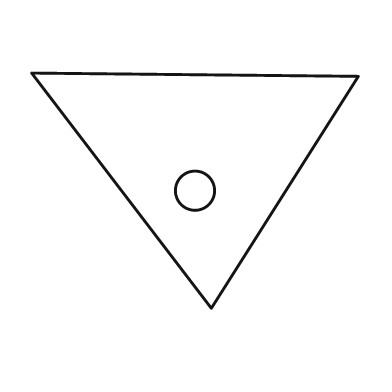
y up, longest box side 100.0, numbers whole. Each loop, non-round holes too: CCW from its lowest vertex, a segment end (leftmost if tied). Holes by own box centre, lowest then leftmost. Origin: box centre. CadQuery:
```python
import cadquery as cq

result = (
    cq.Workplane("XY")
    .moveTo(5.0, -36.0)
    .lineTo(50.0, 35.0)
    .lineTo(-50.0, 36.0)
    .close()
    .moveTo(0.0, 0.0)
    .circle(6.0)
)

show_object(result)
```